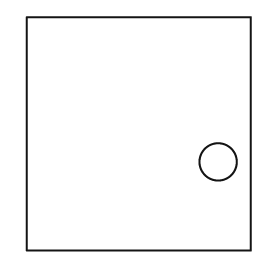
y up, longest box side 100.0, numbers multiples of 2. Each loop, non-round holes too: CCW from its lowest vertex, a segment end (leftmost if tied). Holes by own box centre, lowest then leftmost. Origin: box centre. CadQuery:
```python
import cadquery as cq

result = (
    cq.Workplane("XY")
    .moveTo(-48.0, -50.0)
    .lineTo(48.0, -50.0)
    .lineTo(48.0, 50.0)
    .lineTo(-48.0, 50.0)
    .close()
    .moveTo(34.0, -12.0)
    .circle(8.0)
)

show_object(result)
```